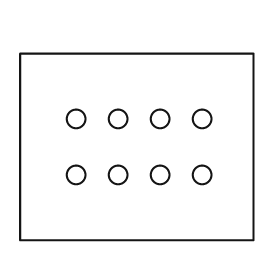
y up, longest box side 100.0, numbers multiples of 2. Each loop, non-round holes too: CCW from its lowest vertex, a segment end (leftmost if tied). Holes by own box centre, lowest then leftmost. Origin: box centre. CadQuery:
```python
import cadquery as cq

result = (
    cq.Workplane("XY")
    .moveTo(-50.0, -40.0)
    .lineTo(50.0, -40.0)
    .lineTo(50.0, 40.0)
    .lineTo(-50.0, 40.0)
    .close()
    .moveTo(-26.0, -12.0)
    .circle(4.0)
    .moveTo(-8.0, -12.0)
    .circle(4.0)
    .moveTo(10.0, -12.0)
    .circle(4.0)
    .moveTo(28.0, -12.0)
    .circle(4.0)
    .moveTo(-26.0, 12.0)
    .circle(4.0)
    .moveTo(-8.0, 12.0)
    .circle(4.0)
    .moveTo(10.0, 12.0)
    .circle(4.0)
    .moveTo(28.0, 12.0)
    .circle(4.0)
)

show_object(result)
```